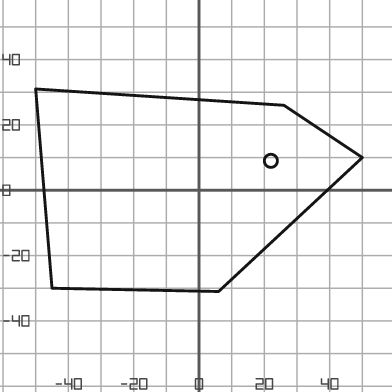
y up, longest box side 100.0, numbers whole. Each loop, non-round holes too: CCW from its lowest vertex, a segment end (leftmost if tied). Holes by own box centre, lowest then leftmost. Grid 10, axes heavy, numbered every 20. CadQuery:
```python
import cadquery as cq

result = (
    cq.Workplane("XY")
    .moveTo(6.0, -31.0)
    .lineTo(50.0, 10.0)
    .lineTo(26.0, 26.0)
    .lineTo(-50.0, 31.0)
    .lineTo(-45.0, -30.0)
    .close()
    .moveTo(22.0, 9.0)
    .circle(2.0)
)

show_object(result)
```